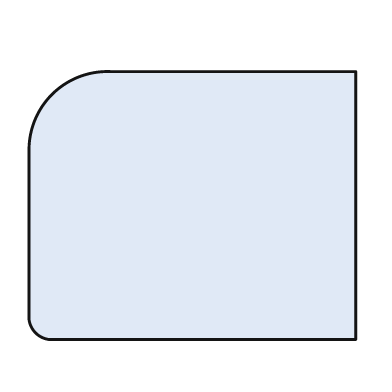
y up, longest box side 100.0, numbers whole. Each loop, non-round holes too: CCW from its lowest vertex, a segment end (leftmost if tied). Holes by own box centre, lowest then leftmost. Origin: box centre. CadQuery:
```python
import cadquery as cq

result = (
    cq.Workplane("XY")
    .moveTo(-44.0, -41.0)
    .lineTo(50.0, -41.0)
    .lineTo(50.0, 41.0)
    .lineTo(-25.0, 41.0)
    .threePointArc((-43.0, 34.0), (-50.0, 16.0))
    .lineTo(-50.0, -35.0)
    .threePointArc((-48.0, -39.0), (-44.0, -41.0))
    .close()
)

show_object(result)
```